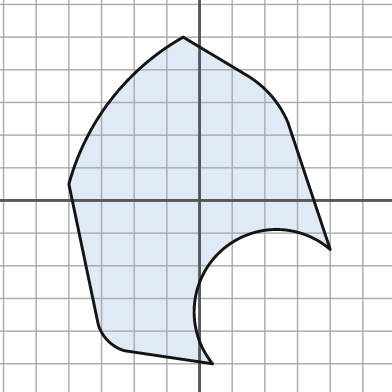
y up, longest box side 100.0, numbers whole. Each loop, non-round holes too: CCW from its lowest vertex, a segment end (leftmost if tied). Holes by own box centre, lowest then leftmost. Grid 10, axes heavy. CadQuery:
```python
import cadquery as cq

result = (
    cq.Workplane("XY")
    .moveTo(4.0, -50.0)
    .threePointArc((6.0, -16.0), (40.0, -15.0))
    .lineTo(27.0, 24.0)
    .threePointArc((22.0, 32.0), (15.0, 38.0))
    .lineTo(-5.0, 50.0)
    .threePointArc((-27.0, 31.0), (-40.0, 5.0))
    .lineTo(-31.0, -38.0)
    .threePointArc((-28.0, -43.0), (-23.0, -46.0))
    .close()
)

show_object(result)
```